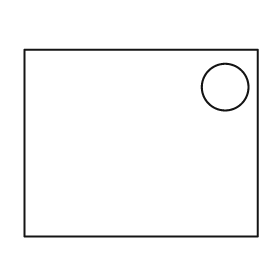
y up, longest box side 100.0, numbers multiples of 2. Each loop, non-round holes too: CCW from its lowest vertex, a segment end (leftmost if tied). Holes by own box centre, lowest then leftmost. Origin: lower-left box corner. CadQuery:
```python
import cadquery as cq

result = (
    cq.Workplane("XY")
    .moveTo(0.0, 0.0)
    .lineTo(100.0, 0.0)
    .lineTo(100.0, 80.0)
    .lineTo(0.0, 80.0)
    .close()
    .moveTo(86.0, 64.0)
    .circle(10.0)
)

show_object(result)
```